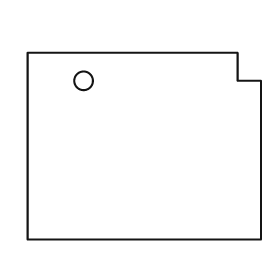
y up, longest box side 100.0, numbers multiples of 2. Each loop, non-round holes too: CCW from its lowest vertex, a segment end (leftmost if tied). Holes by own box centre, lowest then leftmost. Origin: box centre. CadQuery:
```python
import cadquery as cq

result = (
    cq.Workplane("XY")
    .moveTo(-50.0, -40.0)
    .lineTo(50.0, -40.0)
    .lineTo(50.0, 28.0)
    .lineTo(40.0, 28.0)
    .lineTo(40.0, 40.0)
    .lineTo(-50.0, 40.0)
    .close()
    .moveTo(-26.0, 28.0)
    .circle(4.0)
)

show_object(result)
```